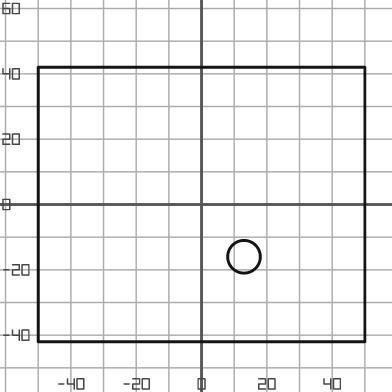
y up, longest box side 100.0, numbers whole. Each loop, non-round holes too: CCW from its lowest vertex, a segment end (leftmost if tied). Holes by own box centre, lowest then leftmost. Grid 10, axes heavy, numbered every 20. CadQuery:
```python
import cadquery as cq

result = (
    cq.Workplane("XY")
    .moveTo(-50.0, -42.0)
    .lineTo(50.0, -42.0)
    .lineTo(50.0, 42.0)
    .lineTo(-50.0, 42.0)
    .close()
    .moveTo(13.0, -16.0)
    .circle(5.0)
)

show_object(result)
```